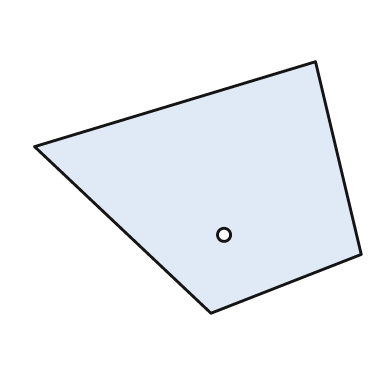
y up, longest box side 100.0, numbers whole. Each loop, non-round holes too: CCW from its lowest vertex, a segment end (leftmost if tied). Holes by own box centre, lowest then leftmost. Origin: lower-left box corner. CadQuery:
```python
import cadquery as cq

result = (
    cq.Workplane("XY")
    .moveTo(54.0, 0.0)
    .lineTo(100.0, 18.0)
    .lineTo(86.0, 77.0)
    .lineTo(0.0, 51.0)
    .close()
    .moveTo(58.0, 24.0)
    .circle(2.0)
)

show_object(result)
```